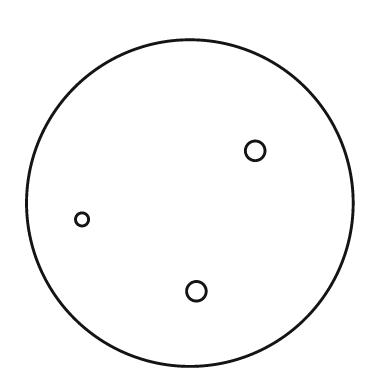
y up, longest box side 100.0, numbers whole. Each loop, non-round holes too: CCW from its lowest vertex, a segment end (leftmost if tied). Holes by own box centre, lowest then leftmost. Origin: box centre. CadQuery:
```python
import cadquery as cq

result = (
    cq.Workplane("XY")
    .moveTo(0.0, 0.0)
    .circle(50.0)
    .moveTo(2.0, -27.0)
    .circle(3.0)
    .moveTo(-33.0, -5.0)
    .circle(2.0)
    .moveTo(20.0, 16.0)
    .circle(3.0)
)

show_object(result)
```